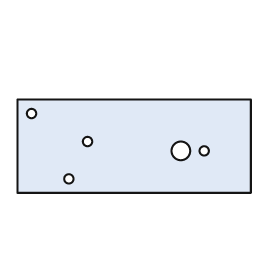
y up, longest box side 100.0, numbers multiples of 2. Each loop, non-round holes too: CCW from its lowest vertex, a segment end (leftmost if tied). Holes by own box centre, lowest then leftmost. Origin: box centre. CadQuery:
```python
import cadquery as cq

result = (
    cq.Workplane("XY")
    .moveTo(-50.0, -20.0)
    .lineTo(50.0, -20.0)
    .lineTo(50.0, 20.0)
    .lineTo(-50.0, 20.0)
    .close()
    .moveTo(-28.0, -14.0)
    .circle(2.0)
    .moveTo(20.0, -2.0)
    .circle(4.0)
    .moveTo(30.0, -2.0)
    .circle(2.0)
    .moveTo(-20.0, 2.0)
    .circle(2.0)
    .moveTo(-44.0, 14.0)
    .circle(2.0)
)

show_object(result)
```